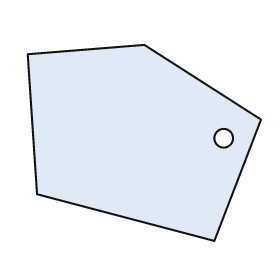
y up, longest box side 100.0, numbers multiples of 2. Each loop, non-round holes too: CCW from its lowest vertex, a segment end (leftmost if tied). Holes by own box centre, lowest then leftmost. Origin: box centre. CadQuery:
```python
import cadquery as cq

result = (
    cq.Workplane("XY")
    .moveTo(30.0, -42.0)
    .lineTo(50.0, 10.0)
    .lineTo(0.0, 42.0)
    .lineTo(-50.0, 38.0)
    .lineTo(-46.0, -22.0)
    .close()
    .moveTo(34.0, 2.0)
    .circle(4.0)
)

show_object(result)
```